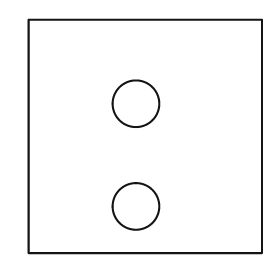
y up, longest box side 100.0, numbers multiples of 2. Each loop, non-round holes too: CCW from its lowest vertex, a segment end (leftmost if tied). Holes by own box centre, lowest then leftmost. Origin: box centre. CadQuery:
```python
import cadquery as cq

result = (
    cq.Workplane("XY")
    .moveTo(-50.0, -50.0)
    .lineTo(50.0, -50.0)
    .lineTo(50.0, 50.0)
    .lineTo(-50.0, 50.0)
    .close()
    .moveTo(-4.0, -30.0)
    .circle(10.0)
    .moveTo(-4.0, 14.0)
    .circle(10.0)
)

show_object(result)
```